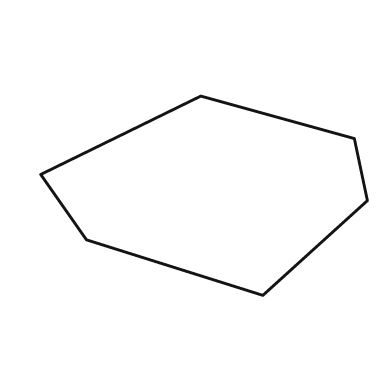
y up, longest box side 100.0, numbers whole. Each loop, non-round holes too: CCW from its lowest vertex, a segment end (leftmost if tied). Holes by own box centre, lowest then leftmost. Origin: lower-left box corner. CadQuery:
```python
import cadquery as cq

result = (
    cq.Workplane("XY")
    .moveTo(68.0, 0.0)
    .lineTo(100.0, 29.0)
    .lineTo(96.0, 48.0)
    .lineTo(49.0, 61.0)
    .lineTo(0.0, 37.0)
    .lineTo(14.0, 17.0)
    .close()
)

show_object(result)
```